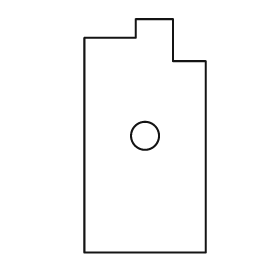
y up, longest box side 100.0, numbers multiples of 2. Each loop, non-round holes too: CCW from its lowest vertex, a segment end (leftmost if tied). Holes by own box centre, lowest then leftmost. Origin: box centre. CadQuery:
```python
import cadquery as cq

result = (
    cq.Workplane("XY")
    .moveTo(-26.0, -50.0)
    .lineTo(26.0, -50.0)
    .lineTo(26.0, 32.0)
    .lineTo(12.0, 32.0)
    .lineTo(12.0, 50.0)
    .lineTo(-4.0, 50.0)
    .lineTo(-4.0, 42.0)
    .lineTo(-26.0, 42.0)
    .close()
    .moveTo(0.0, 0.0)
    .circle(6.0)
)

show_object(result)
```